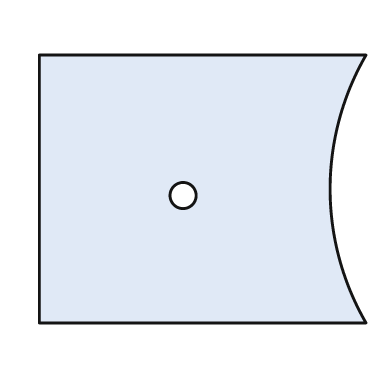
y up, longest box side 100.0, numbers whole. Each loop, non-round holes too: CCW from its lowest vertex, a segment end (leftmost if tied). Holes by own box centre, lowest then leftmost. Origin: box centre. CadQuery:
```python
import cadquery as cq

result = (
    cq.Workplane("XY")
    .moveTo(-50.0, -41.0)
    .lineTo(50.0, -41.0)
    .threePointArc((39.0, 0.0), (50.0, 41.0))
    .lineTo(-50.0, 41.0)
    .close()
    .moveTo(-6.0, -2.0)
    .circle(4.0)
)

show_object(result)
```